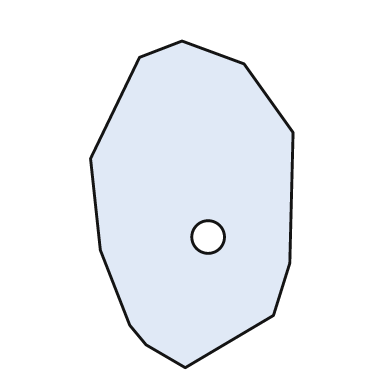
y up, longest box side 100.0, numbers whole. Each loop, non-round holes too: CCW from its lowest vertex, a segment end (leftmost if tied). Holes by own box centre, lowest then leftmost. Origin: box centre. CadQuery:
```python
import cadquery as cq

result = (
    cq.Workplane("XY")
    .moveTo(-2.0, -50.0)
    .lineTo(25.0, -34.0)
    .lineTo(30.0, -18.0)
    .lineTo(31.0, 22.0)
    .lineTo(16.0, 43.0)
    .lineTo(-3.0, 50.0)
    .lineTo(-16.0, 45.0)
    .lineTo(-31.0, 14.0)
    .lineTo(-28.0, -14.0)
    .lineTo(-19.0, -37.0)
    .lineTo(-14.0, -43.0)
    .close()
    .moveTo(5.0, -10.0)
    .circle(5.0)
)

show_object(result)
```